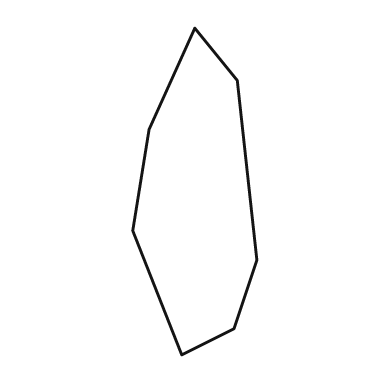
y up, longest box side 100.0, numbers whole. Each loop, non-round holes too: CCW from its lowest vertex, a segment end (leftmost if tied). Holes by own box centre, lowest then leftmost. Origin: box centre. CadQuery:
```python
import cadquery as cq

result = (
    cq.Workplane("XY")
    .moveTo(-4.0, -50.0)
    .lineTo(12.0, -42.0)
    .lineTo(19.0, -21.0)
    .lineTo(13.0, 34.0)
    .lineTo(0.0, 50.0)
    .lineTo(-14.0, 19.0)
    .lineTo(-19.0, -12.0)
    .close()
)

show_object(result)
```